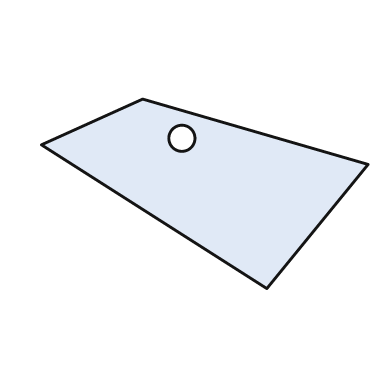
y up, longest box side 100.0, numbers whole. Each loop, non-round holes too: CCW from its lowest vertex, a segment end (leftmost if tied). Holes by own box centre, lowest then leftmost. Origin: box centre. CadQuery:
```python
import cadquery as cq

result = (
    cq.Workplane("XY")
    .moveTo(19.0, -29.0)
    .lineTo(50.0, 9.0)
    .lineTo(-19.0, 29.0)
    .lineTo(-50.0, 15.0)
    .close()
    .moveTo(-7.0, 17.0)
    .circle(4.0)
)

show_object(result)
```